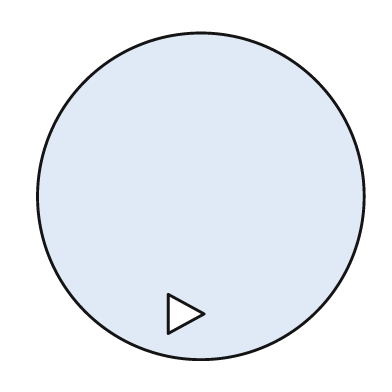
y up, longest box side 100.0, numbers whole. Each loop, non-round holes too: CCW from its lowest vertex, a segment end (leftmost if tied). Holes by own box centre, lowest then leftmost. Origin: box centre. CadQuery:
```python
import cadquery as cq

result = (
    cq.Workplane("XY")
    .moveTo(0.0, 0.0)
    .circle(50.0)
    .moveTo(-10.0, -42.0)
    .lineTo(1.0, -36.0)
    .lineTo(-10.0, -30.0)
    .close()
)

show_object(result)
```